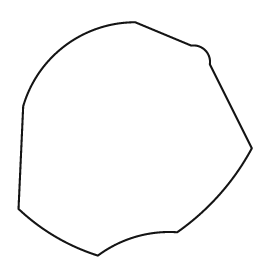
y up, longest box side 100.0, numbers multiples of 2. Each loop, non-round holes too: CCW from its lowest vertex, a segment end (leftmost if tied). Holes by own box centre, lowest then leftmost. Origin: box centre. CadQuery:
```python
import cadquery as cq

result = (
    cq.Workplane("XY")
    .moveTo(-16.0, -50.0)
    .threePointArc((0.0, -42.0), (18.0, -40.0))
    .threePointArc((36.0, -24.0), (50.0, -4.0))
    .lineTo(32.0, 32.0)
    .threePointArc((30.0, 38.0), (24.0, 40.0))
    .lineTo(0.0, 50.0)
    .threePointArc((-30.0, 40.0), (-48.0, 14.0))
    .lineTo(-50.0, -30.0)
    .threePointArc((-34.0, -42.0), (-16.0, -50.0))
    .close()
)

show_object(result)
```